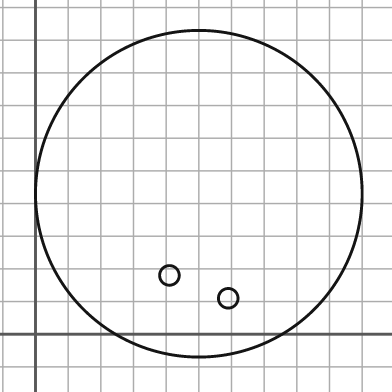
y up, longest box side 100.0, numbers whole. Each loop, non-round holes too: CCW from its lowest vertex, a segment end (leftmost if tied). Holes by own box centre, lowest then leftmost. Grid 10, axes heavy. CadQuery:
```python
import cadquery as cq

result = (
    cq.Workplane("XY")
    .moveTo(50.0, 43.0)
    .circle(50.0)
    .moveTo(59.0, 11.0)
    .circle(3.0)
    .moveTo(41.0, 18.0)
    .circle(3.0)
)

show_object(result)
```